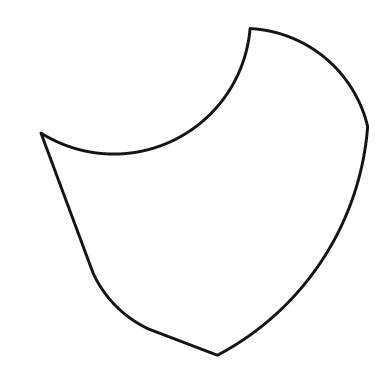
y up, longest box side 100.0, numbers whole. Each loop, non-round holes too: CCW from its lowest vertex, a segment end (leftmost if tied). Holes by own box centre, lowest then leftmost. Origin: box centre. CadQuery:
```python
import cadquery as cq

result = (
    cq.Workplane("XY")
    .moveTo(4.0, -50.0)
    .threePointArc((36.0, -21.0), (50.0, 20.0))
    .threePointArc((37.0, 41.0), (14.0, 50.0))
    .threePointArc((-9.0, 16.0), (-50.0, 18.0))
    .lineTo(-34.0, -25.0)
    .threePointArc((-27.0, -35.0), (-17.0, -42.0))
    .close()
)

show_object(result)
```